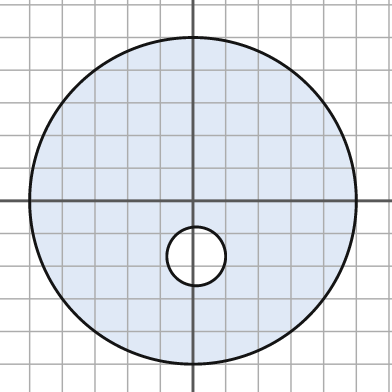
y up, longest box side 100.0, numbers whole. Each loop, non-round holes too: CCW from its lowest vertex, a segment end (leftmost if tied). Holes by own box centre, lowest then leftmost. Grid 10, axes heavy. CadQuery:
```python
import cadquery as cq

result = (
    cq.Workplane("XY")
    .moveTo(0.0, 0.0)
    .circle(50.0)
    .moveTo(1.0, -17.0)
    .circle(9.0)
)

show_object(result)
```